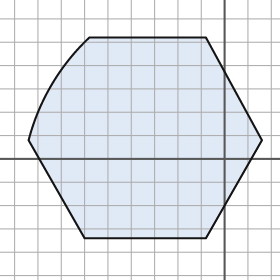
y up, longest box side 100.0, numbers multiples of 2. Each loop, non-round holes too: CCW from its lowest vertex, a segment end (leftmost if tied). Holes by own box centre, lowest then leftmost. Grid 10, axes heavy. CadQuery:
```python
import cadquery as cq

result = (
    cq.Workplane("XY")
    .moveTo(-60.0, -34.0)
    .lineTo(-8.0, -34.0)
    .lineTo(16.0, 8.0)
    .lineTo(-8.0, 52.0)
    .lineTo(-58.0, 52.0)
    .threePointArc((-74.0, 32.0), (-84.0, 8.0))
    .close()
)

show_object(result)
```